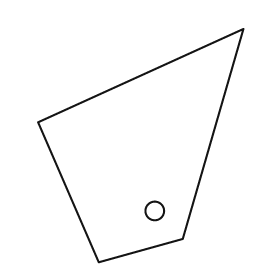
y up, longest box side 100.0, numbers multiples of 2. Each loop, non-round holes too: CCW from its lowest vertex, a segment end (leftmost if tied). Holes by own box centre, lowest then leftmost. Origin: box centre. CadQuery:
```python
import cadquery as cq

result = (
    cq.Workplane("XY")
    .moveTo(-18.0, -50.0)
    .lineTo(18.0, -40.0)
    .lineTo(44.0, 50.0)
    .lineTo(-44.0, 10.0)
    .close()
    .moveTo(6.0, -28.0)
    .circle(4.0)
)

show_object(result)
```